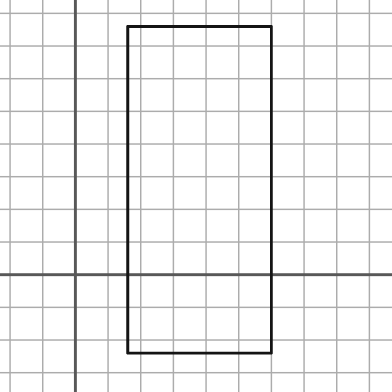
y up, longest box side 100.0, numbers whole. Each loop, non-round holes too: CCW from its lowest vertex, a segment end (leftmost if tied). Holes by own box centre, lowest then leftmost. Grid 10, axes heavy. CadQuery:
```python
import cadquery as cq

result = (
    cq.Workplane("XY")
    .moveTo(16.0, -24.0)
    .lineTo(60.0, -24.0)
    .lineTo(60.0, 76.0)
    .lineTo(16.0, 76.0)
    .close()
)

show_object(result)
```